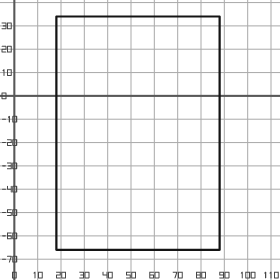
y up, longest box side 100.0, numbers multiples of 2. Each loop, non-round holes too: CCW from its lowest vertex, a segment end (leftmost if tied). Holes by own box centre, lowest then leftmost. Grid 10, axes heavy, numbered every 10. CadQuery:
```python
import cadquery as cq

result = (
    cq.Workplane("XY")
    .moveTo(18.0, -66.0)
    .lineTo(88.0, -66.0)
    .lineTo(88.0, 34.0)
    .lineTo(18.0, 34.0)
    .close()
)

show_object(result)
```